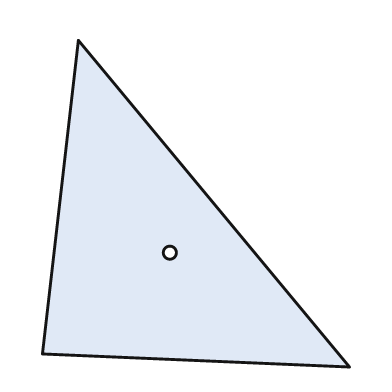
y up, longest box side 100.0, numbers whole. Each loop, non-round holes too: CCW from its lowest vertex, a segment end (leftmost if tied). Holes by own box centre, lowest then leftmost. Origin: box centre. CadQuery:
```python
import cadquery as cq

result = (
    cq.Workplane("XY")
    .moveTo(47.0, -50.0)
    .lineTo(-36.0, 50.0)
    .lineTo(-47.0, -46.0)
    .close()
    .moveTo(-8.0, -15.0)
    .circle(2.0)
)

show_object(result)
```